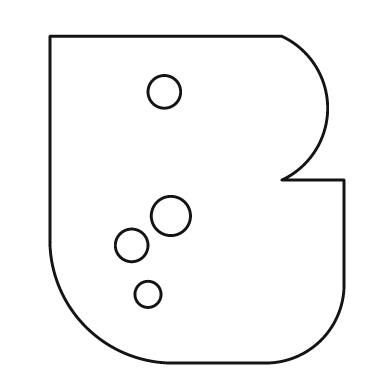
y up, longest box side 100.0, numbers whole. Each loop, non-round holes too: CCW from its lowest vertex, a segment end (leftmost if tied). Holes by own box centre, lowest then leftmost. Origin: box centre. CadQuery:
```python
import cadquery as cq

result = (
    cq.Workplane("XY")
    .moveTo(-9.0, -50.0)
    .lineTo(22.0, -50.0)
    .threePointArc((38.0, -43.0), (45.0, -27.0))
    .lineTo(45.0, 6.0)
    .lineTo(26.0, 6.0)
    .threePointArc((40.0, 28.0), (26.0, 50.0))
    .lineTo(-45.0, 50.0)
    .lineTo(-45.0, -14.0)
    .threePointArc((-34.0, -39.0), (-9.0, -50.0))
    .close()
    .moveTo(-15.0, -29.0)
    .circle(4.0)
    .moveTo(-20.0, -14.0)
    .circle(5.0)
    .moveTo(-8.0, -5.0)
    .circle(6.0)
    .moveTo(-10.0, 33.0)
    .circle(5.0)
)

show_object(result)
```